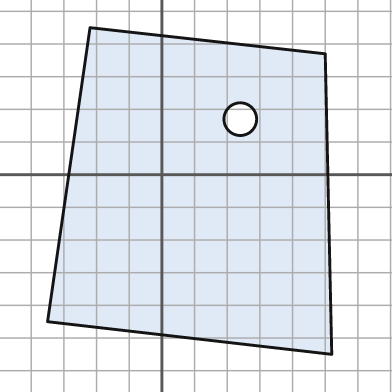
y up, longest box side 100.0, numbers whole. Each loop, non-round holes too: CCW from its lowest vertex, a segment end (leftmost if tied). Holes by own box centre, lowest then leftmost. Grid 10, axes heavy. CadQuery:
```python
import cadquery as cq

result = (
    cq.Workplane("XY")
    .moveTo(52.0, -55.0)
    .lineTo(50.0, 37.0)
    .lineTo(-22.0, 45.0)
    .lineTo(-35.0, -45.0)
    .close()
    .moveTo(24.0, 17.0)
    .circle(5.0)
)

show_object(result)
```